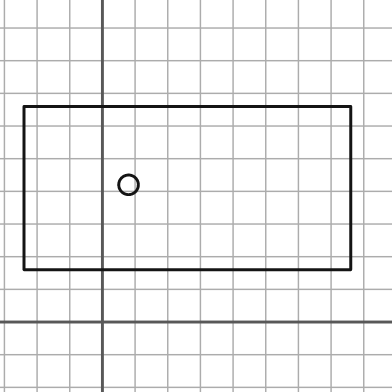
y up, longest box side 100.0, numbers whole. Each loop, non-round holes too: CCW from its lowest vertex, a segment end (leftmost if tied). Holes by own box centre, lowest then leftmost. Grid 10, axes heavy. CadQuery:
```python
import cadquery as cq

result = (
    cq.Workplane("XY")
    .moveTo(-24.0, 16.0)
    .lineTo(76.0, 16.0)
    .lineTo(76.0, 66.0)
    .lineTo(-24.0, 66.0)
    .close()
    .moveTo(8.0, 42.0)
    .circle(3.0)
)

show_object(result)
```